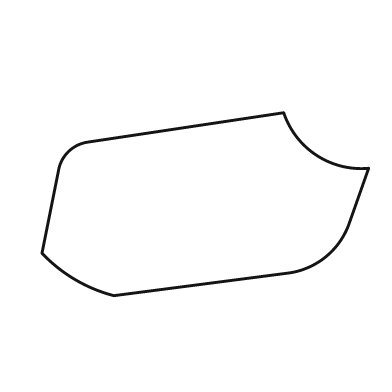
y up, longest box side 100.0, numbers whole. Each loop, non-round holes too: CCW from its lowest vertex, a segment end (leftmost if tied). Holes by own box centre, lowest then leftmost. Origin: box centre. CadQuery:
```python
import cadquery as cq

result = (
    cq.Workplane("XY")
    .moveTo(-28.0, -28.0)
    .lineTo(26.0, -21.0)
    .threePointArc((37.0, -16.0), (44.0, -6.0))
    .lineTo(50.0, 11.0)
    .threePointArc((34.0, 15.0), (24.0, 28.0))
    .lineTo(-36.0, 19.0)
    .threePointArc((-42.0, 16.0), (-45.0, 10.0))
    .lineTo(-50.0, -15.0)
    .threePointArc((-40.0, -23.0), (-28.0, -28.0))
    .close()
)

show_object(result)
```